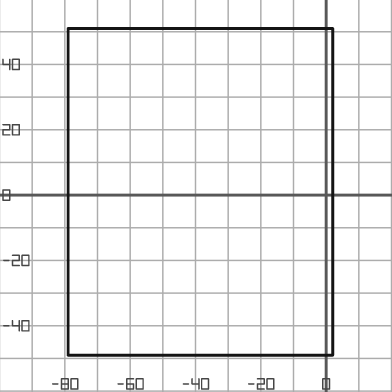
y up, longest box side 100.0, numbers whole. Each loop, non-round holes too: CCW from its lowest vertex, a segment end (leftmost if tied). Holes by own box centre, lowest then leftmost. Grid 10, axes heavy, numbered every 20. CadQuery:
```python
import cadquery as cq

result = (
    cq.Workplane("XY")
    .moveTo(-79.0, -49.0)
    .lineTo(2.0, -49.0)
    .lineTo(2.0, 51.0)
    .lineTo(-79.0, 51.0)
    .close()
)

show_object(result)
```